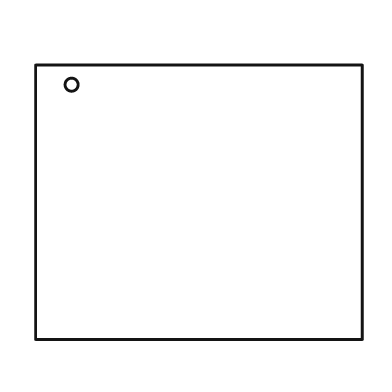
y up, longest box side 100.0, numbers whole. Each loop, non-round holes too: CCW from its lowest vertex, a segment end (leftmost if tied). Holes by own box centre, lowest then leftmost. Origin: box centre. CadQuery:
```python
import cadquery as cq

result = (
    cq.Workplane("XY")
    .moveTo(-50.0, -42.0)
    .lineTo(50.0, -42.0)
    .lineTo(50.0, 42.0)
    .lineTo(-50.0, 42.0)
    .close()
    .moveTo(-39.0, 36.0)
    .circle(2.0)
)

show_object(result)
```